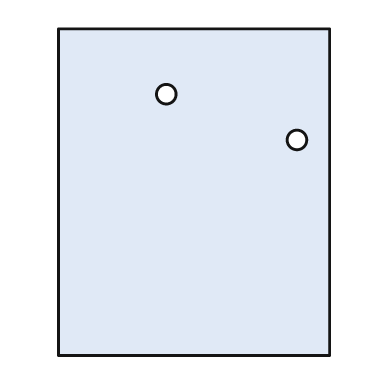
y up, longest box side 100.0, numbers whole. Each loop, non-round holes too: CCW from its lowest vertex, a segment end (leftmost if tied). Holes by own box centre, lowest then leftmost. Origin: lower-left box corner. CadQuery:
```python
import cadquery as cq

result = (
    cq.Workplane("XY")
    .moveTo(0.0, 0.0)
    .lineTo(83.0, 0.0)
    .lineTo(83.0, 100.0)
    .lineTo(0.0, 100.0)
    .close()
    .moveTo(73.0, 66.0)
    .circle(3.0)
    .moveTo(33.0, 80.0)
    .circle(3.0)
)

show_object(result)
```